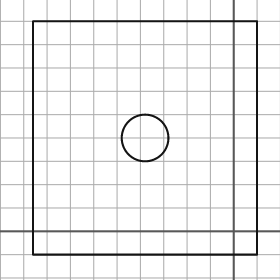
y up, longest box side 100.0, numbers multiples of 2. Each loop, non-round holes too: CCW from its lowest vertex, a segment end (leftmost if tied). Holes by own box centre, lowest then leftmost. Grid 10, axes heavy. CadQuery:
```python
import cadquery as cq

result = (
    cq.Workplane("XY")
    .moveTo(-86.0, -10.0)
    .lineTo(10.0, -10.0)
    .lineTo(10.0, 90.0)
    .lineTo(-86.0, 90.0)
    .close()
    .moveTo(-38.0, 40.0)
    .circle(10.0)
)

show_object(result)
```